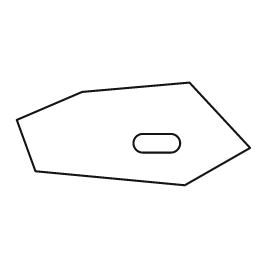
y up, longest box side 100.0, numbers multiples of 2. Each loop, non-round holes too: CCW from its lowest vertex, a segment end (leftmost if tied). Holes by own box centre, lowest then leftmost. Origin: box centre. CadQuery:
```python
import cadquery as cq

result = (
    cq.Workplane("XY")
    .moveTo(22.0, -22.0)
    .lineTo(50.0, -6.0)
    .lineTo(24.0, 22.0)
    .lineTo(-22.0, 18.0)
    .lineTo(-50.0, 6.0)
    .lineTo(-42.0, -16.0)
    .close()
    .moveTo(4.0, -8.0)
    .lineTo(16.0, -8.0)
    .threePointArc((20.0, -4.0), (16.0, 0.0))
    .lineTo(4.0, 0.0)
    .threePointArc((0.0, -4.0), (4.0, -8.0))
    .close()
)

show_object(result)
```